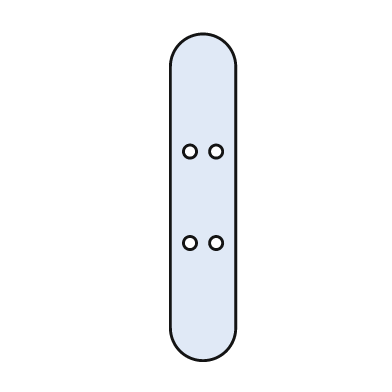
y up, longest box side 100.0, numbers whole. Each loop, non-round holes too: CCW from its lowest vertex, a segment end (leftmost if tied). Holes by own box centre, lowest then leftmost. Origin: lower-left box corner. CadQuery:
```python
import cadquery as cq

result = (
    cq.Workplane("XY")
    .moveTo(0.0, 10.0)
    .threePointArc((10.0, 0.0), (20.0, 10.0))
    .lineTo(20.0, 90.0)
    .threePointArc((10.0, 100.0), (0.0, 90.0))
    .close()
    .moveTo(6.0, 36.0)
    .circle(2.0)
    .moveTo(14.0, 36.0)
    .circle(2.0)
    .moveTo(6.0, 64.0)
    .circle(2.0)
    .moveTo(14.0, 64.0)
    .circle(2.0)
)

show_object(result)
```